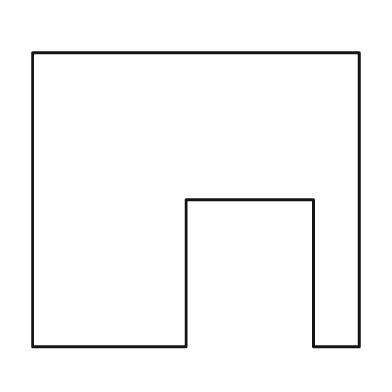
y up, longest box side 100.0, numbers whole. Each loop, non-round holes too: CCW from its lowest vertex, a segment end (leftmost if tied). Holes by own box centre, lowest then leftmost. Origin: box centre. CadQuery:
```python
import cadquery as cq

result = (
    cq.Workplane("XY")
    .moveTo(-50.0, -45.0)
    .lineTo(-3.0, -45.0)
    .lineTo(-3.0, 0.0)
    .lineTo(36.0, 0.0)
    .lineTo(36.0, -45.0)
    .lineTo(50.0, -45.0)
    .lineTo(50.0, 45.0)
    .lineTo(-50.0, 45.0)
    .close()
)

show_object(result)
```